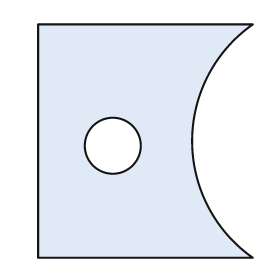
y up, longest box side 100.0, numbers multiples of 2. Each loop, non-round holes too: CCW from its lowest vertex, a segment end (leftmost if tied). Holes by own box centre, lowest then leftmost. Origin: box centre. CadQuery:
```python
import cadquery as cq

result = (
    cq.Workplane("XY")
    .moveTo(-46.0, -50.0)
    .lineTo(46.0, -50.0)
    .threePointArc((20.0, 0.0), (46.0, 50.0))
    .lineTo(-46.0, 50.0)
    .close()
    .moveTo(-14.0, -2.0)
    .circle(12.0)
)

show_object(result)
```